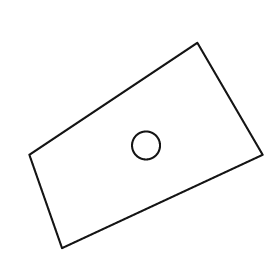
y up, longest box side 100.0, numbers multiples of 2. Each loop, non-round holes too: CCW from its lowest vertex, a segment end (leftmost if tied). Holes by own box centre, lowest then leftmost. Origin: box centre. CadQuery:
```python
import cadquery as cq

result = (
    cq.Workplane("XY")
    .moveTo(-36.0, -44.0)
    .lineTo(50.0, -4.0)
    .lineTo(22.0, 44.0)
    .lineTo(-50.0, -4.0)
    .close()
    .moveTo(0.0, 0.0)
    .circle(6.0)
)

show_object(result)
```